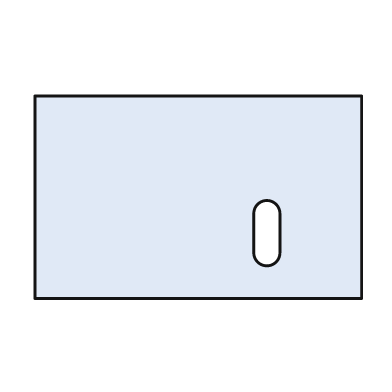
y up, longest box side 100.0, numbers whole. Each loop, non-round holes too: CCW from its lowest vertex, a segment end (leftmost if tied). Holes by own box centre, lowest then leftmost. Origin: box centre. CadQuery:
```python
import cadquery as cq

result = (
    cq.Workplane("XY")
    .moveTo(-50.0, -31.0)
    .lineTo(50.0, -31.0)
    .lineTo(50.0, 31.0)
    .lineTo(-50.0, 31.0)
    .close()
    .moveTo(17.0, -17.0)
    .threePointArc((21.0, -21.0), (25.0, -17.0))
    .lineTo(25.0, -5.0)
    .threePointArc((21.0, -1.0), (17.0, -5.0))
    .close()
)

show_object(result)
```